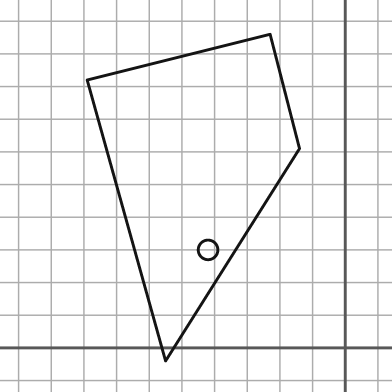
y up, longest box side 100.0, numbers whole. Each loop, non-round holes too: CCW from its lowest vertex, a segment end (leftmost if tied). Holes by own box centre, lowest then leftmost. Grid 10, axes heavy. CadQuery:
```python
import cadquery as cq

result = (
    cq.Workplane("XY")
    .moveTo(-55.0, -4.0)
    .lineTo(-14.0, 61.0)
    .lineTo(-23.0, 96.0)
    .lineTo(-79.0, 82.0)
    .close()
    .moveTo(-42.0, 30.0)
    .circle(3.0)
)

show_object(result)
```